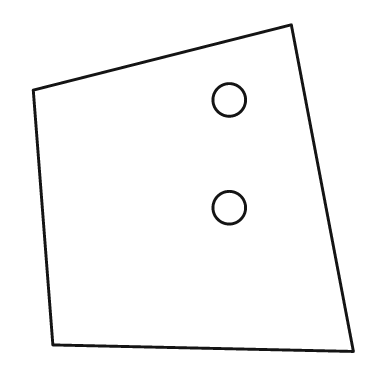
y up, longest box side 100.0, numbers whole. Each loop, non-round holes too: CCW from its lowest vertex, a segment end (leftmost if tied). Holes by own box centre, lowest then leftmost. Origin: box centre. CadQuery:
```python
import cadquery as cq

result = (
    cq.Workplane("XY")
    .moveTo(49.0, -50.0)
    .lineTo(30.0, 50.0)
    .lineTo(-49.0, 30.0)
    .lineTo(-43.0, -48.0)
    .close()
    .moveTo(11.0, -6.0)
    .circle(5.0)
    .moveTo(11.0, 27.0)
    .circle(5.0)
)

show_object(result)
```